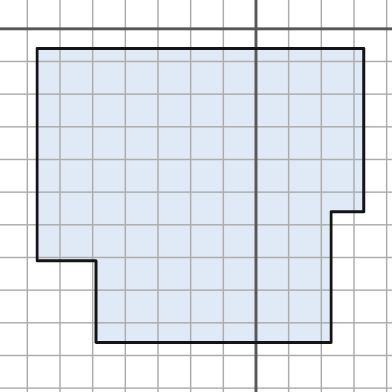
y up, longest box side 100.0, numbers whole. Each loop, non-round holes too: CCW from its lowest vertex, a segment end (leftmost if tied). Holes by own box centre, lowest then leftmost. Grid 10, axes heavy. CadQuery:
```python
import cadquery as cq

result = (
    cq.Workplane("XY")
    .moveTo(-49.0, -96.0)
    .lineTo(23.0, -96.0)
    .lineTo(23.0, -56.0)
    .lineTo(33.0, -56.0)
    .lineTo(33.0, -6.0)
    .lineTo(-67.0, -6.0)
    .lineTo(-67.0, -71.0)
    .lineTo(-49.0, -71.0)
    .close()
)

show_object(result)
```